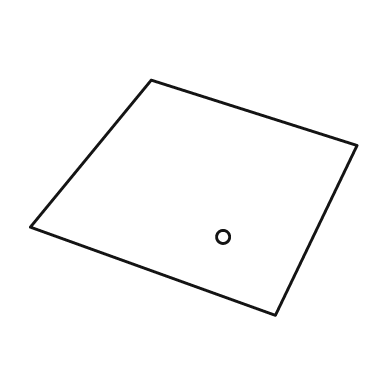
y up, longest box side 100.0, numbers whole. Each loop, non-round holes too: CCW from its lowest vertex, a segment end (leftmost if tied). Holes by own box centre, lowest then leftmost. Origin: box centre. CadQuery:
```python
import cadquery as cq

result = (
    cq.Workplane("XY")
    .moveTo(25.0, -36.0)
    .lineTo(50.0, 16.0)
    .lineTo(-13.0, 36.0)
    .lineTo(-50.0, -9.0)
    .close()
    .moveTo(9.0, -12.0)
    .circle(2.0)
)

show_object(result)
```